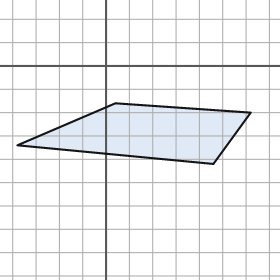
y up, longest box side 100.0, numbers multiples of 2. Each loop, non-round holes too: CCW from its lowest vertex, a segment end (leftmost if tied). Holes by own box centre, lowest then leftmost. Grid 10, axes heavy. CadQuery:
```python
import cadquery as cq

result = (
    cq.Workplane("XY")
    .moveTo(46.0, -42.0)
    .lineTo(62.0, -20.0)
    .lineTo(4.0, -16.0)
    .lineTo(-38.0, -34.0)
    .close()
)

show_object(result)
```